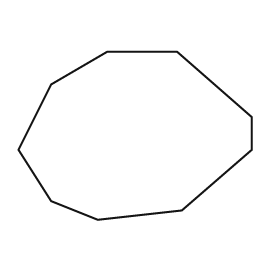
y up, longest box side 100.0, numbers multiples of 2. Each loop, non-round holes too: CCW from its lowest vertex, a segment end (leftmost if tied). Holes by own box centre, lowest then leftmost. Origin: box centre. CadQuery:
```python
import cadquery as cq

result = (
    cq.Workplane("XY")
    .moveTo(-16.0, -36.0)
    .lineTo(20.0, -32.0)
    .lineTo(50.0, -6.0)
    .lineTo(50.0, 8.0)
    .lineTo(18.0, 36.0)
    .lineTo(-12.0, 36.0)
    .lineTo(-36.0, 22.0)
    .lineTo(-50.0, -6.0)
    .lineTo(-36.0, -28.0)
    .close()
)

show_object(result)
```